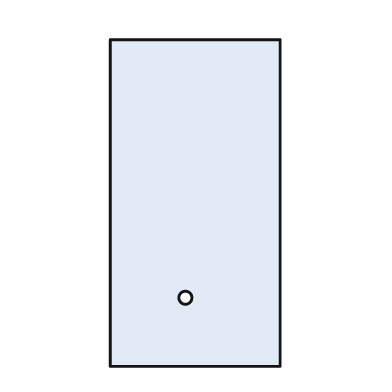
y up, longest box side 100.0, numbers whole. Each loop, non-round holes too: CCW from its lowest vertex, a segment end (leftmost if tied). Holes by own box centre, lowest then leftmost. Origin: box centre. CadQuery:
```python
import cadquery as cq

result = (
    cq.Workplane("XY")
    .moveTo(-26.0, -50.0)
    .lineTo(26.0, -50.0)
    .lineTo(26.0, 50.0)
    .lineTo(-26.0, 50.0)
    .close()
    .moveTo(-3.0, -29.0)
    .circle(2.0)
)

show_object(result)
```